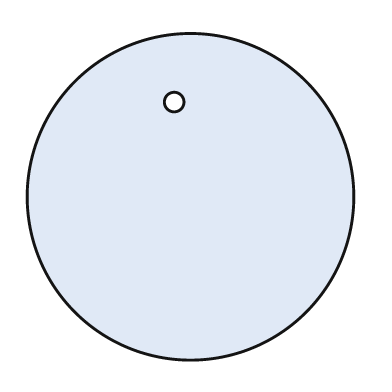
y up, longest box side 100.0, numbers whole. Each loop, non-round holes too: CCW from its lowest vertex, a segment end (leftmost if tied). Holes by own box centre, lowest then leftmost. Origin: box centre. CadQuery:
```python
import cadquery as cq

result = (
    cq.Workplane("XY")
    .moveTo(0.0, 0.0)
    .circle(50.0)
    .moveTo(-5.0, 29.0)
    .circle(3.0)
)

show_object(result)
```